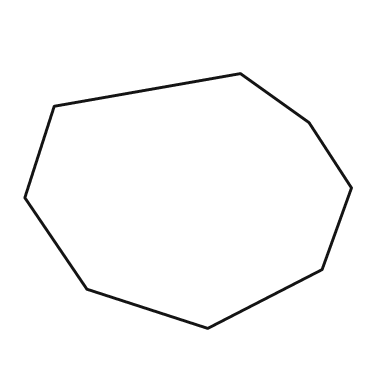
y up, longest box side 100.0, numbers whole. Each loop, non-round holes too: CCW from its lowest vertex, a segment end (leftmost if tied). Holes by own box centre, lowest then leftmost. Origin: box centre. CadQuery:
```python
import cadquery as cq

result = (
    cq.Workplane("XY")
    .moveTo(6.0, -39.0)
    .lineTo(41.0, -21.0)
    .lineTo(50.0, 4.0)
    .lineTo(37.0, 24.0)
    .lineTo(16.0, 39.0)
    .lineTo(-41.0, 29.0)
    .lineTo(-50.0, 1.0)
    .lineTo(-31.0, -27.0)
    .close()
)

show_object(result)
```